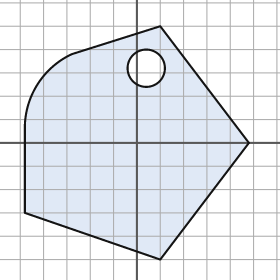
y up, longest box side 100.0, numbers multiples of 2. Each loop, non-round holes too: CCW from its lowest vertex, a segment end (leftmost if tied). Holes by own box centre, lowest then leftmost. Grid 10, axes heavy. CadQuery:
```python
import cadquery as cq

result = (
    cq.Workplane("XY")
    .moveTo(10.0, -50.0)
    .lineTo(48.0, 0.0)
    .lineTo(10.0, 50.0)
    .lineTo(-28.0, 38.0)
    .threePointArc((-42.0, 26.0), (-48.0, 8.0))
    .lineTo(-48.0, -30.0)
    .close()
    .moveTo(4.0, 32.0)
    .circle(8.0)
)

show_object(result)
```